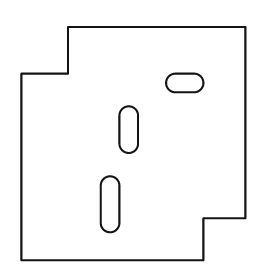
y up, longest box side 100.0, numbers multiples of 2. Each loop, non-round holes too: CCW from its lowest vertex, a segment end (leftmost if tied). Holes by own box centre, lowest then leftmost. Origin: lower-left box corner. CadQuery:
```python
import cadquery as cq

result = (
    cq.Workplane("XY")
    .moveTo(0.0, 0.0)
    .lineTo(78.0, 0.0)
    .lineTo(78.0, 18.0)
    .lineTo(96.0, 18.0)
    .lineTo(96.0, 100.0)
    .lineTo(20.0, 100.0)
    .lineTo(20.0, 80.0)
    .lineTo(0.0, 80.0)
    .close()
    .moveTo(34.0, 16.0)
    .threePointArc((38.0, 12.0), (42.0, 16.0))
    .lineTo(42.0, 32.0)
    .threePointArc((38.0, 36.0), (34.0, 32.0))
    .close()
    .moveTo(42.0, 50.0)
    .threePointArc((46.0, 46.0), (50.0, 50.0))
    .lineTo(50.0, 62.0)
    .threePointArc((46.0, 66.0), (42.0, 62.0))
    .close()
    .moveTo(66.0, 72.0)
    .lineTo(74.0, 72.0)
    .threePointArc((78.0, 76.0), (74.0, 80.0))
    .lineTo(66.0, 80.0)
    .threePointArc((62.0, 76.0), (66.0, 72.0))
    .close()
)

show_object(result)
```